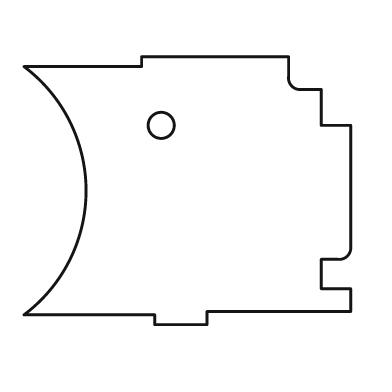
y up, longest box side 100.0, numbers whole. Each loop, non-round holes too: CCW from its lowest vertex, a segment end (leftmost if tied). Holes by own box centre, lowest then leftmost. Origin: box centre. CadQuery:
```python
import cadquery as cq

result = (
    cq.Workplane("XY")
    .moveTo(-10.0, -41.0)
    .lineTo(6.0, -41.0)
    .lineTo(6.0, -37.0)
    .lineTo(50.0, -37.0)
    .lineTo(50.0, -30.0)
    .lineTo(41.0, -30.0)
    .lineTo(41.0, -21.0)
    .lineTo(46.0, -21.0)
    .threePointArc((49.0, -20.0), (50.0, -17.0))
    .lineTo(50.0, 20.0)
    .lineTo(41.0, 20.0)
    .lineTo(41.0, 31.0)
    .lineTo(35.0, 31.0)
    .threePointArc((32.0, 32.0), (31.0, 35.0))
    .lineTo(31.0, 41.0)
    .lineTo(-14.0, 41.0)
    .lineTo(-14.0, 38.0)
    .lineTo(-50.0, 38.0)
    .threePointArc((-31.0, 0.0), (-50.0, -38.0))
    .lineTo(-10.0, -38.0)
    .close()
    .moveTo(-8.0, 20.0)
    .circle(4.0)
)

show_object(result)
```